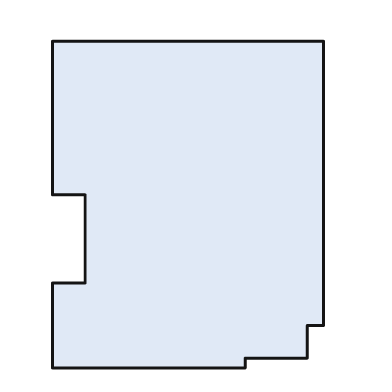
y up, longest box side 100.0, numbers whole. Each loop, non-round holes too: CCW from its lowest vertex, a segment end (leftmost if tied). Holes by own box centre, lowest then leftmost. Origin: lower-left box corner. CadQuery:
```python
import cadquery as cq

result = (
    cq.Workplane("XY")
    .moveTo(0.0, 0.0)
    .lineTo(59.0, 0.0)
    .lineTo(59.0, 3.0)
    .lineTo(78.0, 3.0)
    .lineTo(78.0, 13.0)
    .lineTo(83.0, 13.0)
    .lineTo(83.0, 100.0)
    .lineTo(0.0, 100.0)
    .lineTo(0.0, 53.0)
    .lineTo(10.0, 53.0)
    .lineTo(10.0, 26.0)
    .lineTo(0.0, 26.0)
    .close()
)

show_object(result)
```